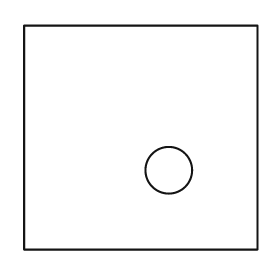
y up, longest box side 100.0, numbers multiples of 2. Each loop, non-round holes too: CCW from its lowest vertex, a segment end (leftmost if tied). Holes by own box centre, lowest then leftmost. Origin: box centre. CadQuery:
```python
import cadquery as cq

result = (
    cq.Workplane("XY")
    .moveTo(-50.0, -48.0)
    .lineTo(50.0, -48.0)
    .lineTo(50.0, 48.0)
    .lineTo(-50.0, 48.0)
    .close()
    .moveTo(12.0, -14.0)
    .circle(10.0)
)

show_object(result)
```